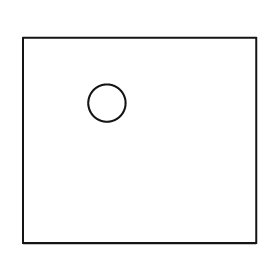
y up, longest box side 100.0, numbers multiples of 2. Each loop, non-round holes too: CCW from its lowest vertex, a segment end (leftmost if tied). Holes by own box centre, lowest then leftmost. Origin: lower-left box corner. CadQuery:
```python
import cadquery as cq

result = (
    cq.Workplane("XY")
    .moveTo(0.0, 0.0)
    .lineTo(100.0, 0.0)
    .lineTo(100.0, 88.0)
    .lineTo(0.0, 88.0)
    .close()
    .moveTo(36.0, 60.0)
    .circle(8.0)
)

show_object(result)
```